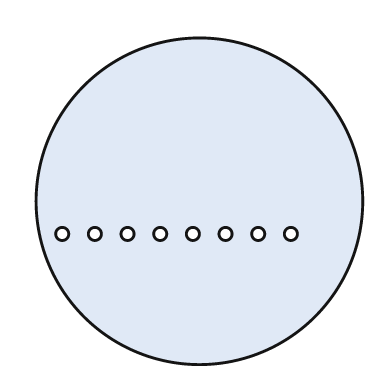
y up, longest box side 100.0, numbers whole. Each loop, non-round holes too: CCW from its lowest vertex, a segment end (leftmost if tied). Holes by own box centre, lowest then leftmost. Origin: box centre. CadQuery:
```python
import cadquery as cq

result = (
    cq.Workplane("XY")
    .moveTo(0.0, 0.0)
    .circle(50.0)
    .moveTo(-42.0, -10.0)
    .circle(2.0)
    .moveTo(-32.0, -10.0)
    .circle(2.0)
    .moveTo(-22.0, -10.0)
    .circle(2.0)
    .moveTo(-12.0, -10.0)
    .circle(2.0)
    .moveTo(-2.0, -10.0)
    .circle(2.0)
    .moveTo(8.0, -10.0)
    .circle(2.0)
    .moveTo(18.0, -10.0)
    .circle(2.0)
    .moveTo(28.0, -10.0)
    .circle(2.0)
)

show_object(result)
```